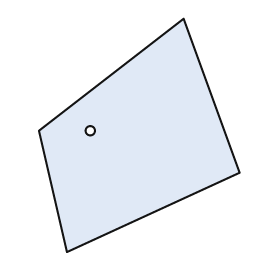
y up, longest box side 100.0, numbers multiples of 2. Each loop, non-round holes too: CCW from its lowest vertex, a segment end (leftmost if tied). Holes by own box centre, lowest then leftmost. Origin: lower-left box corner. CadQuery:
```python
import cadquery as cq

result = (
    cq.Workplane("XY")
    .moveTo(12.0, 0.0)
    .lineTo(86.0, 34.0)
    .lineTo(62.0, 100.0)
    .lineTo(0.0, 52.0)
    .close()
    .moveTo(22.0, 52.0)
    .circle(2.0)
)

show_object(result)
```